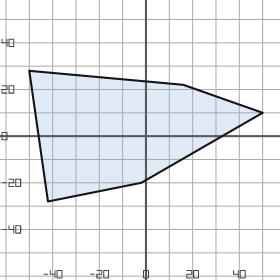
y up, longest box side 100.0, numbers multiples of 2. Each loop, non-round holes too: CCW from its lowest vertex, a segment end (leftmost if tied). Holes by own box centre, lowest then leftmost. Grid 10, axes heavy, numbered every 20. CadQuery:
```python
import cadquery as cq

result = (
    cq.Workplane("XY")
    .moveTo(-42.0, -28.0)
    .lineTo(-2.0, -20.0)
    .lineTo(50.0, 10.0)
    .lineTo(16.0, 22.0)
    .lineTo(-50.0, 28.0)
    .close()
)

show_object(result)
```